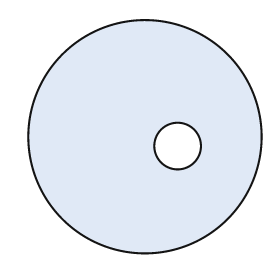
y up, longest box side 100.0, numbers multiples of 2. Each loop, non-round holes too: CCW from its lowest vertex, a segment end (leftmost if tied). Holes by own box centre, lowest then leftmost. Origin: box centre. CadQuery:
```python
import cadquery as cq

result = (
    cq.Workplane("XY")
    .moveTo(0.0, 0.0)
    .circle(50.0)
    .moveTo(14.0, -4.0)
    .circle(10.0)
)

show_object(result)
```